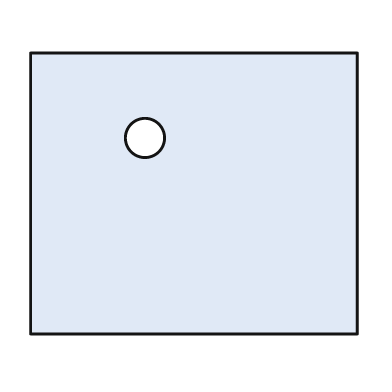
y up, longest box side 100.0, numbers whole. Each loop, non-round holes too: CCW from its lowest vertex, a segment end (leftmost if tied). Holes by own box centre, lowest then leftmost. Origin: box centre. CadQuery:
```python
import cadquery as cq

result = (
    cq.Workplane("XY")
    .moveTo(-50.0, -43.0)
    .lineTo(50.0, -43.0)
    .lineTo(50.0, 43.0)
    .lineTo(-50.0, 43.0)
    .close()
    .moveTo(-15.0, 17.0)
    .circle(6.0)
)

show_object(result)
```